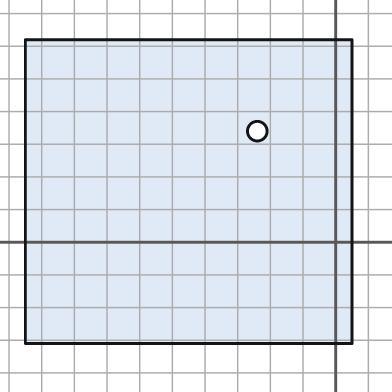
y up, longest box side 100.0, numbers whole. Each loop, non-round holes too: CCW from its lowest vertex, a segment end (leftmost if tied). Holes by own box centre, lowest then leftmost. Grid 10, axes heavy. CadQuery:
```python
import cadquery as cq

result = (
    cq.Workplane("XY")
    .moveTo(-95.0, -31.0)
    .lineTo(5.0, -31.0)
    .lineTo(5.0, 62.0)
    .lineTo(-95.0, 62.0)
    .close()
    .moveTo(-24.0, 34.0)
    .circle(3.0)
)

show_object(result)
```